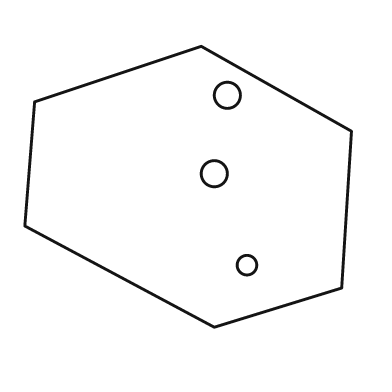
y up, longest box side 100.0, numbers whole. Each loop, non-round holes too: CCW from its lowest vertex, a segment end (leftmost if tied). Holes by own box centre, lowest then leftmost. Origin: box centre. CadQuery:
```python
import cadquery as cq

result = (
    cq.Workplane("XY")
    .moveTo(8.0, -43.0)
    .lineTo(47.0, -31.0)
    .lineTo(50.0, 17.0)
    .lineTo(4.0, 43.0)
    .lineTo(-47.0, 26.0)
    .lineTo(-50.0, -12.0)
    .close()
    .moveTo(18.0, -24.0)
    .circle(3.0)
    .moveTo(8.0, 4.0)
    .circle(4.0)
    .moveTo(12.0, 28.0)
    .circle(4.0)
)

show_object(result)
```